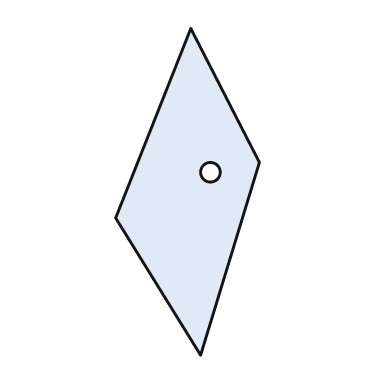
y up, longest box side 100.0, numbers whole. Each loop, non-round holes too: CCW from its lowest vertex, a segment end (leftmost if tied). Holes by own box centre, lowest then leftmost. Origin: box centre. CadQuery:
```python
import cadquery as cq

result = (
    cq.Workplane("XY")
    .moveTo(4.0, -50.0)
    .lineTo(22.0, 9.0)
    .lineTo(1.0, 50.0)
    .lineTo(-22.0, -8.0)
    .close()
    .moveTo(7.0, 6.0)
    .circle(3.0)
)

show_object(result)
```